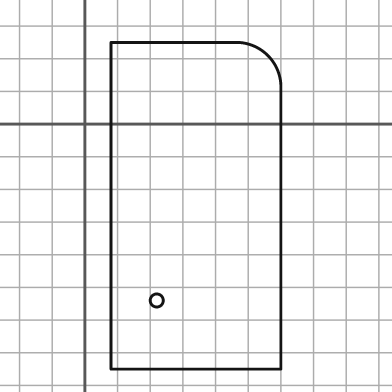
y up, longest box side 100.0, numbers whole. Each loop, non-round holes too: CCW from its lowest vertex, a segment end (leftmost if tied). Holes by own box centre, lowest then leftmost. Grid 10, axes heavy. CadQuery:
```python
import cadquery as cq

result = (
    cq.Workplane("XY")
    .moveTo(8.0, -75.0)
    .lineTo(60.0, -75.0)
    .lineTo(60.0, 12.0)
    .threePointArc((56.0, 21.0), (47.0, 25.0))
    .lineTo(8.0, 25.0)
    .close()
    .moveTo(22.0, -54.0)
    .circle(2.0)
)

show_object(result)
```